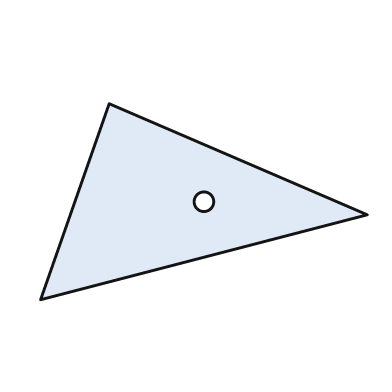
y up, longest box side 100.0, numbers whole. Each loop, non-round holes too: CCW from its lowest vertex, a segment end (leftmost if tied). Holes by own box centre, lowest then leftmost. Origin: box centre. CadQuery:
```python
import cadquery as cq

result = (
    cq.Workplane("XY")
    .moveTo(-50.0, -30.0)
    .lineTo(50.0, -4.0)
    .lineTo(-29.0, 30.0)
    .close()
    .moveTo(0.0, 0.0)
    .circle(3.0)
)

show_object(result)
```